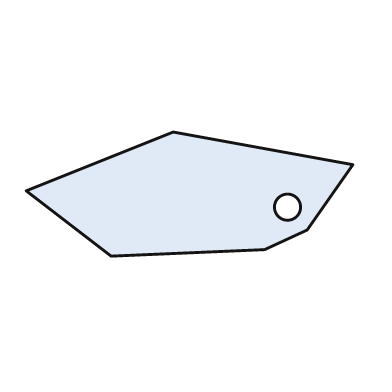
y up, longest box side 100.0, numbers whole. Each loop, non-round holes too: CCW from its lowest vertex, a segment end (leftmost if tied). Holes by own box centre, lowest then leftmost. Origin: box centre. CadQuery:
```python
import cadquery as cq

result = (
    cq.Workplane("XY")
    .moveTo(-24.0, -19.0)
    .lineTo(23.0, -17.0)
    .lineTo(36.0, -11.0)
    .lineTo(50.0, 9.0)
    .lineTo(-5.0, 19.0)
    .lineTo(-50.0, 1.0)
    .close()
    .moveTo(30.0, -4.0)
    .circle(4.0)
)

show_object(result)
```